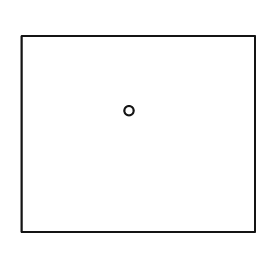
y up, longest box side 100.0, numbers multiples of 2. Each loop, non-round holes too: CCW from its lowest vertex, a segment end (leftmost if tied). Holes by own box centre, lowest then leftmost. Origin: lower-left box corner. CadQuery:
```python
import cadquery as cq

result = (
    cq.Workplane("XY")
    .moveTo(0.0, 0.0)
    .lineTo(100.0, 0.0)
    .lineTo(100.0, 84.0)
    .lineTo(0.0, 84.0)
    .close()
    .moveTo(46.0, 52.0)
    .circle(2.0)
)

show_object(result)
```